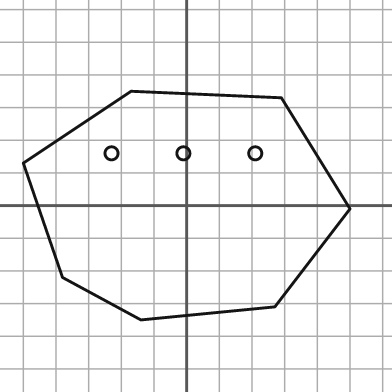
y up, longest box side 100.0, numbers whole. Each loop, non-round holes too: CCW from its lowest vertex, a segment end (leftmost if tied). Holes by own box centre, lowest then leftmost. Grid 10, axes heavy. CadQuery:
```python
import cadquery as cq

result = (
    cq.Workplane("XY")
    .moveTo(-14.0, -35.0)
    .lineTo(27.0, -31.0)
    .lineTo(50.0, -1.0)
    .lineTo(29.0, 33.0)
    .lineTo(-17.0, 35.0)
    .lineTo(-50.0, 13.0)
    .lineTo(-38.0, -22.0)
    .close()
    .moveTo(-23.0, 16.0)
    .circle(2.0)
    .moveTo(-1.0, 16.0)
    .circle(2.0)
    .moveTo(21.0, 16.0)
    .circle(2.0)
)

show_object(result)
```